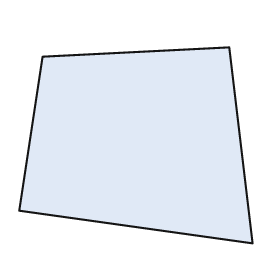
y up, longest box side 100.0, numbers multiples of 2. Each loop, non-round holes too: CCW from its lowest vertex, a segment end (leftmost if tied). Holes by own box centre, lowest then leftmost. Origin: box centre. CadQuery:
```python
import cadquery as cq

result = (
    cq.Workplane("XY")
    .moveTo(50.0, -42.0)
    .lineTo(40.0, 42.0)
    .lineTo(-40.0, 38.0)
    .lineTo(-50.0, -28.0)
    .close()
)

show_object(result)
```